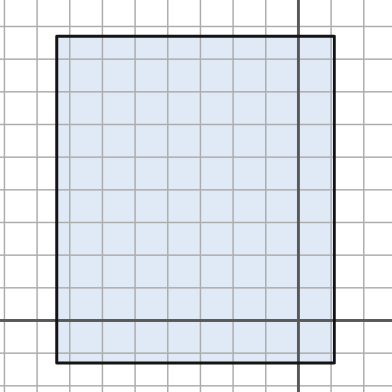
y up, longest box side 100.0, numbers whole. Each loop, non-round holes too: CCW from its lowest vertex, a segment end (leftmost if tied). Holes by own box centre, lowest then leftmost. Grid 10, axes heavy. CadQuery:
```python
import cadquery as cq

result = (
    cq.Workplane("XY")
    .moveTo(-74.0, -13.0)
    .lineTo(11.0, -13.0)
    .lineTo(11.0, 87.0)
    .lineTo(-74.0, 87.0)
    .close()
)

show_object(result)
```